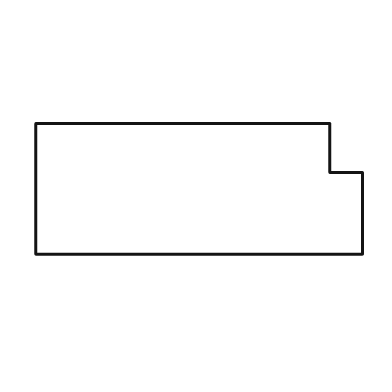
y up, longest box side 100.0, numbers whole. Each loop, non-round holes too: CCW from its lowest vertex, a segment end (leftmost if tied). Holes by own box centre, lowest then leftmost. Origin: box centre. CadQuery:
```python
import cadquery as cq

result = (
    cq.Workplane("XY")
    .moveTo(-50.0, -20.0)
    .lineTo(50.0, -20.0)
    .lineTo(50.0, 5.0)
    .lineTo(40.0, 5.0)
    .lineTo(40.0, 20.0)
    .lineTo(-50.0, 20.0)
    .close()
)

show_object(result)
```